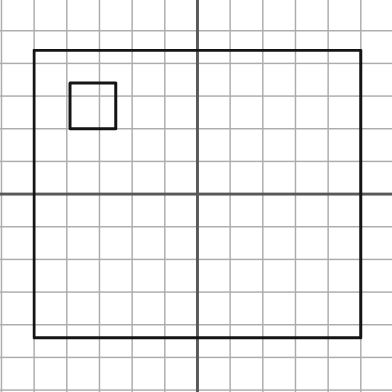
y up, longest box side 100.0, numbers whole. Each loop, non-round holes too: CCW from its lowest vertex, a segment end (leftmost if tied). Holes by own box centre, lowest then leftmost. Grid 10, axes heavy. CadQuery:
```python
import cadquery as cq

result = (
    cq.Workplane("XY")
    .moveTo(-50.0, -44.0)
    .lineTo(50.0, -44.0)
    .lineTo(50.0, 44.0)
    .lineTo(-50.0, 44.0)
    .close()
    .moveTo(-39.0, 20.0)
    .lineTo(-25.0, 20.0)
    .lineTo(-25.0, 34.0)
    .lineTo(-39.0, 34.0)
    .close()
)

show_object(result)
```